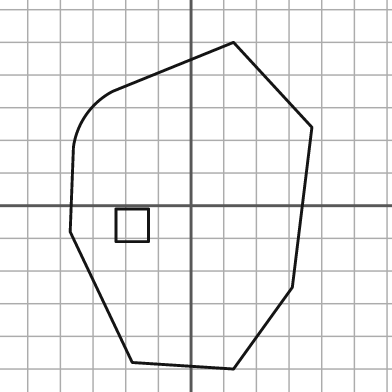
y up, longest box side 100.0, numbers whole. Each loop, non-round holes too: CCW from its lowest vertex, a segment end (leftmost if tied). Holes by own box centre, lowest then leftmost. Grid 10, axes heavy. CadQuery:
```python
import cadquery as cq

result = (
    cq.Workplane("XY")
    .moveTo(13.0, -50.0)
    .lineTo(31.0, -25.0)
    .lineTo(37.0, 24.0)
    .lineTo(13.0, 50.0)
    .lineTo(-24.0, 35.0)
    .threePointArc((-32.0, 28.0), (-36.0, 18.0))
    .lineTo(-37.0, -8.0)
    .lineTo(-18.0, -48.0)
    .close()
    .moveTo(-23.0, -11.0)
    .lineTo(-13.0, -11.0)
    .lineTo(-13.0, -1.0)
    .lineTo(-23.0, -1.0)
    .close()
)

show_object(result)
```